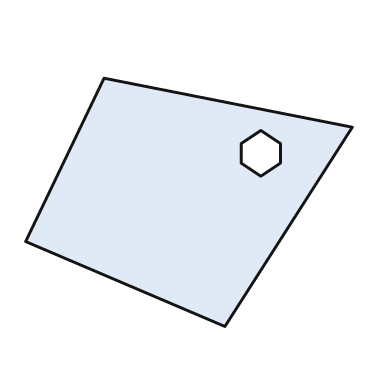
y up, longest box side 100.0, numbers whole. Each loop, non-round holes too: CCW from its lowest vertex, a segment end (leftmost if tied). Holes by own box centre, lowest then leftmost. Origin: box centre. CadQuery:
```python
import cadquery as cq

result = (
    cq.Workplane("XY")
    .moveTo(11.0, -38.0)
    .lineTo(50.0, 23.0)
    .lineTo(-26.0, 38.0)
    .lineTo(-50.0, -12.0)
    .close()
    .moveTo(22.0, 8.0)
    .lineTo(28.0, 12.0)
    .lineTo(28.0, 18.0)
    .lineTo(22.0, 22.0)
    .lineTo(16.0, 18.0)
    .lineTo(16.0, 12.0)
    .close()
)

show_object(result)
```